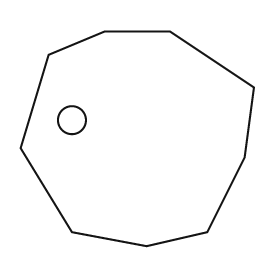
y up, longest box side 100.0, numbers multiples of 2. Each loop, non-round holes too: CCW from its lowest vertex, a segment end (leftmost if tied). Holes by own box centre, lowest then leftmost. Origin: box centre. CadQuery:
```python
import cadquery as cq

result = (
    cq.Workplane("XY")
    .moveTo(4.0, -46.0)
    .lineTo(30.0, -40.0)
    .lineTo(46.0, -8.0)
    .lineTo(50.0, 22.0)
    .lineTo(14.0, 46.0)
    .lineTo(-14.0, 46.0)
    .lineTo(-38.0, 36.0)
    .lineTo(-50.0, -4.0)
    .lineTo(-28.0, -40.0)
    .close()
    .moveTo(-28.0, 8.0)
    .circle(6.0)
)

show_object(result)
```